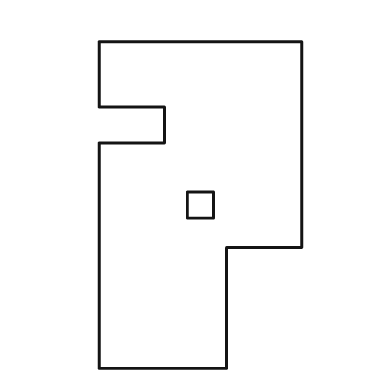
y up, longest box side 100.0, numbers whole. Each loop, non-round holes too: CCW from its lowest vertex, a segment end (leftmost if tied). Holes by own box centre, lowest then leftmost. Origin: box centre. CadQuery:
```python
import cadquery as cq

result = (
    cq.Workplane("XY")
    .moveTo(-31.0, -50.0)
    .lineTo(8.0, -50.0)
    .lineTo(8.0, -13.0)
    .lineTo(31.0, -13.0)
    .lineTo(31.0, 50.0)
    .lineTo(-31.0, 50.0)
    .lineTo(-31.0, 30.0)
    .lineTo(-11.0, 30.0)
    .lineTo(-11.0, 19.0)
    .lineTo(-31.0, 19.0)
    .close()
    .moveTo(-4.0, -4.0)
    .lineTo(4.0, -4.0)
    .lineTo(4.0, 4.0)
    .lineTo(-4.0, 4.0)
    .close()
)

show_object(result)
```